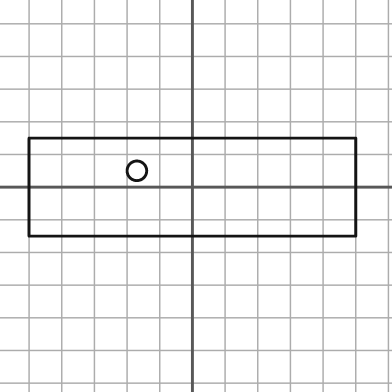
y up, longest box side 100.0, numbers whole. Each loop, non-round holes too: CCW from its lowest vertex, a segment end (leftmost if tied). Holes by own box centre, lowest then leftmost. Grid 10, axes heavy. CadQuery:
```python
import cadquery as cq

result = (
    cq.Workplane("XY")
    .moveTo(-50.0, -15.0)
    .lineTo(50.0, -15.0)
    .lineTo(50.0, 15.0)
    .lineTo(-50.0, 15.0)
    .close()
    .moveTo(-17.0, 5.0)
    .circle(3.0)
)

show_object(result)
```